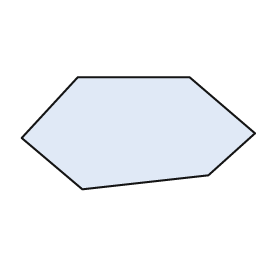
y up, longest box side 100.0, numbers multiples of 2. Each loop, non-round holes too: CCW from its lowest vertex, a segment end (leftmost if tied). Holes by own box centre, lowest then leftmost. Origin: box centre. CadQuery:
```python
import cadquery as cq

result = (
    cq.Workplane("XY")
    .moveTo(-24.0, -24.0)
    .lineTo(30.0, -18.0)
    .lineTo(50.0, 0.0)
    .lineTo(22.0, 24.0)
    .lineTo(-26.0, 24.0)
    .lineTo(-50.0, -2.0)
    .close()
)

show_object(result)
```